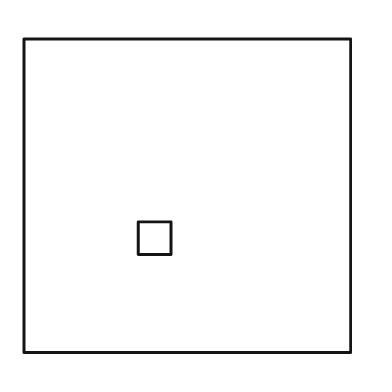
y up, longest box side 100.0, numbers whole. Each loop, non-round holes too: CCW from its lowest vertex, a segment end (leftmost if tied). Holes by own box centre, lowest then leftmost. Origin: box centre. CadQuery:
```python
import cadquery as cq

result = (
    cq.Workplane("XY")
    .moveTo(-50.0, -48.0)
    .lineTo(50.0, -48.0)
    .lineTo(50.0, 48.0)
    .lineTo(-50.0, 48.0)
    .close()
    .moveTo(-15.0, -18.0)
    .lineTo(-5.0, -18.0)
    .lineTo(-5.0, -8.0)
    .lineTo(-15.0, -8.0)
    .close()
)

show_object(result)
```